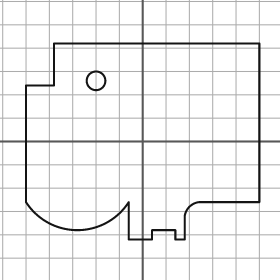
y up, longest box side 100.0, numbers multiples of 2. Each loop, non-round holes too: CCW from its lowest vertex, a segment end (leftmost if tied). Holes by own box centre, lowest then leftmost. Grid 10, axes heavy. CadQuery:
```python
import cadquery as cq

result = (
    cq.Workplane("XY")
    .moveTo(-6.0, -42.0)
    .lineTo(4.0, -42.0)
    .lineTo(4.0, -38.0)
    .lineTo(14.0, -38.0)
    .lineTo(14.0, -42.0)
    .lineTo(18.0, -42.0)
    .lineTo(18.0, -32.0)
    .threePointArc((20.0, -28.0), (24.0, -26.0))
    .lineTo(50.0, -26.0)
    .lineTo(50.0, 42.0)
    .lineTo(-38.0, 42.0)
    .lineTo(-38.0, 24.0)
    .lineTo(-50.0, 24.0)
    .lineTo(-50.0, -26.0)
    .threePointArc((-28.0, -38.0), (-6.0, -26.0))
    .close()
    .moveTo(-20.0, 26.0)
    .circle(4.0)
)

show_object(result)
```